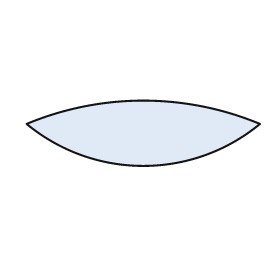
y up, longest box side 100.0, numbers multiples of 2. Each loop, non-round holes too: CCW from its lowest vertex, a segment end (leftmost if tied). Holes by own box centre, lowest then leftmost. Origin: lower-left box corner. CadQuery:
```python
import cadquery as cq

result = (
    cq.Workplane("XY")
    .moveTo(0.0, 18.0)
    .threePointArc((50.0, 0.0), (100.0, 18.0))
    .threePointArc((50.0, 28.0), (0.0, 18.0))
    .close()
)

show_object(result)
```